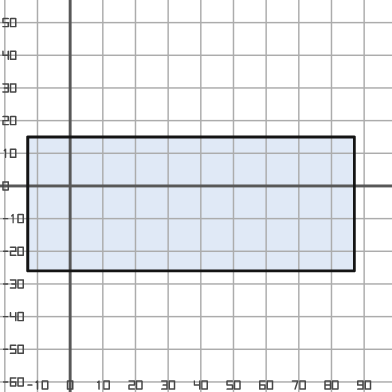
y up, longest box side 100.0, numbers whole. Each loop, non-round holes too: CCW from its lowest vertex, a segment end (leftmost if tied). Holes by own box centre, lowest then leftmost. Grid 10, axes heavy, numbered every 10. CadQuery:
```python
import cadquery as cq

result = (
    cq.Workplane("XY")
    .moveTo(-13.0, -26.0)
    .lineTo(87.0, -26.0)
    .lineTo(87.0, 15.0)
    .lineTo(-13.0, 15.0)
    .close()
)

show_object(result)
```